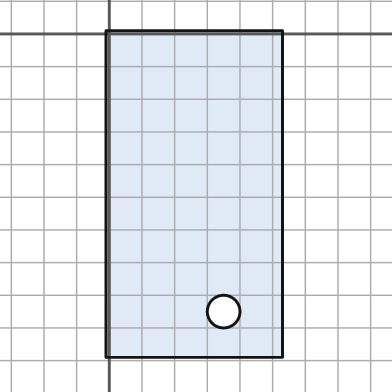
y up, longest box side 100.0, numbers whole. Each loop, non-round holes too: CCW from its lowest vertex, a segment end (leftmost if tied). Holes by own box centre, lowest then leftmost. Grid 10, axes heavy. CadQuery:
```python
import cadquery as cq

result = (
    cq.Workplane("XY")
    .moveTo(-1.0, -99.0)
    .lineTo(53.0, -99.0)
    .lineTo(53.0, 1.0)
    .lineTo(-1.0, 1.0)
    .close()
    .moveTo(35.0, -85.0)
    .circle(5.0)
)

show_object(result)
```